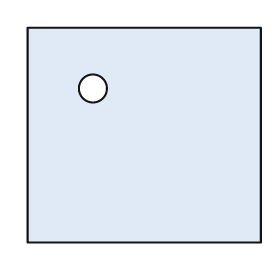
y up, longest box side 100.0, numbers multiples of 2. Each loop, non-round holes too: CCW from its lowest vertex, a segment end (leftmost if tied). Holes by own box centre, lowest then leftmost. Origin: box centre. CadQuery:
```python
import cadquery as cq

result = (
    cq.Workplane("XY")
    .moveTo(-50.0, -46.0)
    .lineTo(50.0, -46.0)
    .lineTo(50.0, 46.0)
    .lineTo(-50.0, 46.0)
    .close()
    .moveTo(-22.0, 20.0)
    .circle(6.0)
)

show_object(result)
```